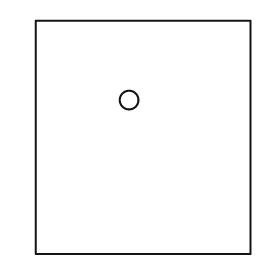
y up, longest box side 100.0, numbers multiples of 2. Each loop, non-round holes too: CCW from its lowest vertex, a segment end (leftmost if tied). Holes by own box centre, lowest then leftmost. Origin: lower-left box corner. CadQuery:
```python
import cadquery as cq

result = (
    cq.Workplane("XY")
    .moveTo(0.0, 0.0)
    .lineTo(92.0, 0.0)
    .lineTo(92.0, 100.0)
    .lineTo(0.0, 100.0)
    .close()
    .moveTo(40.0, 66.0)
    .circle(4.0)
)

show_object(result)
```